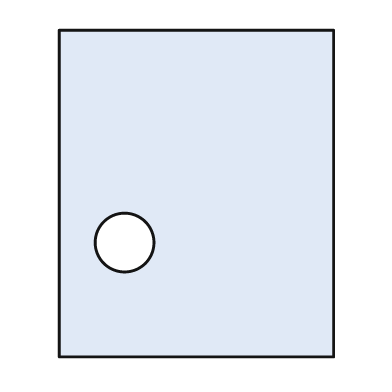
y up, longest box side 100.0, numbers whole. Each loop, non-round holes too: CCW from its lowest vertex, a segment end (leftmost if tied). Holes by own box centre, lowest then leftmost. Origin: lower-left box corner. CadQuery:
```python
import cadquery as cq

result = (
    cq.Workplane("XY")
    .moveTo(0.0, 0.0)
    .lineTo(84.0, 0.0)
    .lineTo(84.0, 100.0)
    .lineTo(0.0, 100.0)
    .close()
    .moveTo(20.0, 35.0)
    .circle(9.0)
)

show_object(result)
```